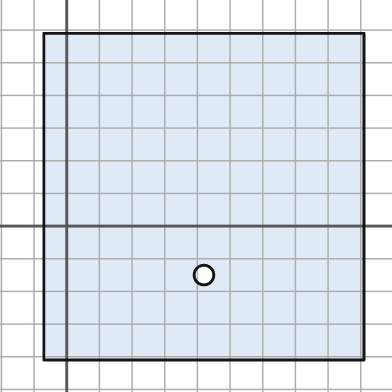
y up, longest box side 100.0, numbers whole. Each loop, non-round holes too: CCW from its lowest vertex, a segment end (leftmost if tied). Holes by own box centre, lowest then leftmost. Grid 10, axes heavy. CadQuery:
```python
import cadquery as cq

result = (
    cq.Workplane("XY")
    .moveTo(-7.0, -41.0)
    .lineTo(91.0, -41.0)
    .lineTo(91.0, 59.0)
    .lineTo(-7.0, 59.0)
    .close()
    .moveTo(42.0, -15.0)
    .circle(3.0)
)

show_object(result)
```